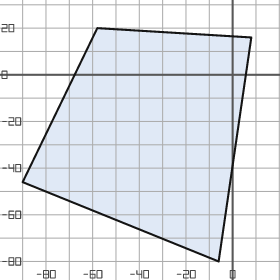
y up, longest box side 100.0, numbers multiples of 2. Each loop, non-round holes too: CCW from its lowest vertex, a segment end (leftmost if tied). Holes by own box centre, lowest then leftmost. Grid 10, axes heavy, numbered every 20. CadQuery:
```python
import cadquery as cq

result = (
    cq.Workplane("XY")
    .moveTo(-6.0, -80.0)
    .lineTo(8.0, 16.0)
    .lineTo(-58.0, 20.0)
    .lineTo(-90.0, -46.0)
    .close()
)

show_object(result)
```